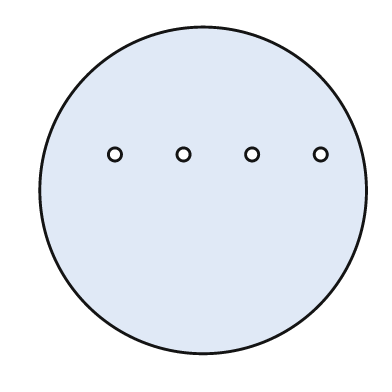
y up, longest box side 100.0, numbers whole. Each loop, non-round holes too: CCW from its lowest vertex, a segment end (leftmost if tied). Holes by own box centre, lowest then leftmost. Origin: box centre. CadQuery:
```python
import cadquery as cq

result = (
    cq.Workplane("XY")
    .moveTo(0.0, 0.0)
    .circle(50.0)
    .moveTo(-27.0, 11.0)
    .circle(2.0)
    .moveTo(-6.0, 11.0)
    .circle(2.0)
    .moveTo(15.0, 11.0)
    .circle(2.0)
    .moveTo(36.0, 11.0)
    .circle(2.0)
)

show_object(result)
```